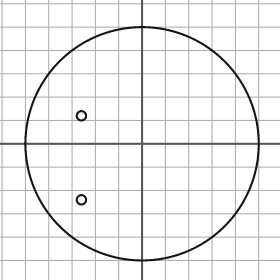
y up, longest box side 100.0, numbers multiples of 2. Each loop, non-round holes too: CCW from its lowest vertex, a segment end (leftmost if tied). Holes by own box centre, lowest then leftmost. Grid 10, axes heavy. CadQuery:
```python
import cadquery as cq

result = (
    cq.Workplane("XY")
    .moveTo(0.0, 0.0)
    .circle(50.0)
    .moveTo(-26.0, -24.0)
    .circle(2.0)
    .moveTo(-26.0, 12.0)
    .circle(2.0)
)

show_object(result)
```